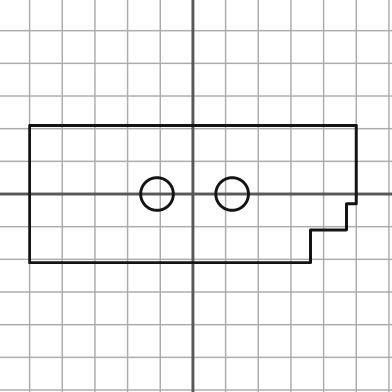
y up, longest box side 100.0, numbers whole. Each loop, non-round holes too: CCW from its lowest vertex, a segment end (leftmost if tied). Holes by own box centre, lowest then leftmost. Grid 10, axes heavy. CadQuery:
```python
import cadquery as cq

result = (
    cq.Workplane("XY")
    .moveTo(-50.0, -21.0)
    .lineTo(36.0, -21.0)
    .lineTo(36.0, -11.0)
    .lineTo(47.0, -11.0)
    .lineTo(47.0, -3.0)
    .lineTo(50.0, -3.0)
    .lineTo(50.0, 21.0)
    .lineTo(-50.0, 21.0)
    .close()
    .moveTo(-11.0, 0.0)
    .circle(5.0)
    .moveTo(12.0, 0.0)
    .circle(5.0)
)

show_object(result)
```